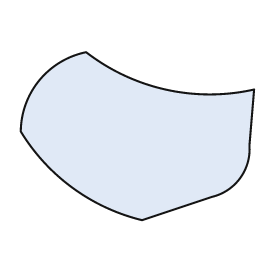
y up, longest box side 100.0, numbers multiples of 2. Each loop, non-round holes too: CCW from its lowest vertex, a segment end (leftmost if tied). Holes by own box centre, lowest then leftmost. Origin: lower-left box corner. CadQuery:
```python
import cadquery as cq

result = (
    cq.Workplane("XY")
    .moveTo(52.0, 0.0)
    .lineTo(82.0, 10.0)
    .threePointArc((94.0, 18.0), (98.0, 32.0))
    .lineTo(100.0, 56.0)
    .threePointArc((62.0, 56.0), (28.0, 72.0))
    .threePointArc((8.0, 60.0), (0.0, 38.0))
    .threePointArc((22.0, 14.0), (52.0, 0.0))
    .close()
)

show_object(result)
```